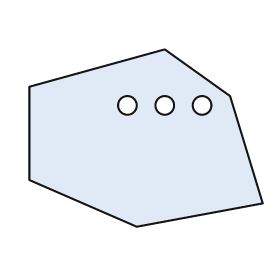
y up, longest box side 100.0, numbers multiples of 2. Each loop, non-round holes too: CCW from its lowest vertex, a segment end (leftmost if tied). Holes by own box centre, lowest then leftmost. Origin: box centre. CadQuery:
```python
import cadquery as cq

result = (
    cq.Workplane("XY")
    .moveTo(-4.0, -38.0)
    .lineTo(50.0, -28.0)
    .lineTo(36.0, 18.0)
    .lineTo(8.0, 38.0)
    .lineTo(-50.0, 22.0)
    .lineTo(-50.0, -18.0)
    .close()
    .moveTo(-8.0, 14.0)
    .circle(4.0)
    .moveTo(8.0, 14.0)
    .circle(4.0)
    .moveTo(24.0, 14.0)
    .circle(4.0)
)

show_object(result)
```